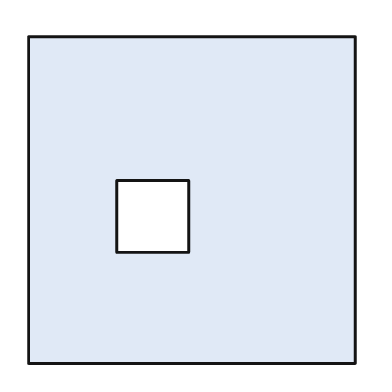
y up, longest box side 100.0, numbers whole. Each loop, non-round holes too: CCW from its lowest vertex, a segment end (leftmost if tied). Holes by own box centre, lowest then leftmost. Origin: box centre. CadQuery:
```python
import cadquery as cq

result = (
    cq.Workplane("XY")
    .moveTo(-50.0, -50.0)
    .lineTo(50.0, -50.0)
    .lineTo(50.0, 50.0)
    .lineTo(-50.0, 50.0)
    .close()
    .moveTo(-23.0, -16.0)
    .lineTo(-1.0, -16.0)
    .lineTo(-1.0, 6.0)
    .lineTo(-23.0, 6.0)
    .close()
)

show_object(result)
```